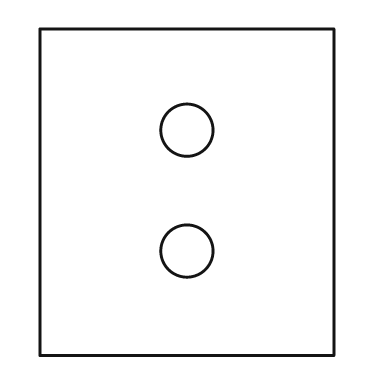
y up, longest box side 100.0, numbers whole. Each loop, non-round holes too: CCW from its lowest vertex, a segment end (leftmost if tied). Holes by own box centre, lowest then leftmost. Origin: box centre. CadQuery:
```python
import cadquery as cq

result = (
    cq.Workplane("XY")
    .moveTo(-45.0, -50.0)
    .lineTo(45.0, -50.0)
    .lineTo(45.0, 50.0)
    .lineTo(-45.0, 50.0)
    .close()
    .moveTo(0.0, -18.0)
    .circle(8.0)
    .moveTo(0.0, 19.0)
    .circle(8.0)
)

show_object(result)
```